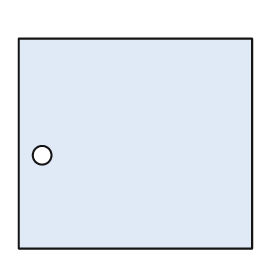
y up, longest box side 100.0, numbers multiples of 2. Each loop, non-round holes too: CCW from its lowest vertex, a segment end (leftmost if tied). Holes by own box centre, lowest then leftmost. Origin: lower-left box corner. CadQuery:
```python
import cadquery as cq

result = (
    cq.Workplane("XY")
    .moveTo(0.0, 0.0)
    .lineTo(100.0, 0.0)
    .lineTo(100.0, 90.0)
    .lineTo(0.0, 90.0)
    .close()
    .moveTo(10.0, 40.0)
    .circle(4.0)
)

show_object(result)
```